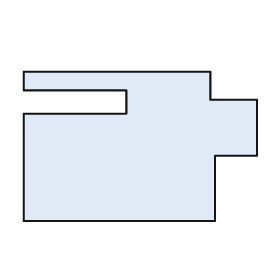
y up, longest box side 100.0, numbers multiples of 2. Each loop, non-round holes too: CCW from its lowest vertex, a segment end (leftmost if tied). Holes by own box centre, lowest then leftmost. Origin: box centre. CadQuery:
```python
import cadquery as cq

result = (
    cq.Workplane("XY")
    .moveTo(-50.0, -32.0)
    .lineTo(32.0, -32.0)
    .lineTo(32.0, -4.0)
    .lineTo(50.0, -4.0)
    .lineTo(50.0, 20.0)
    .lineTo(30.0, 20.0)
    .lineTo(30.0, 32.0)
    .lineTo(-50.0, 32.0)
    .lineTo(-50.0, 24.0)
    .lineTo(-6.0, 24.0)
    .lineTo(-6.0, 14.0)
    .lineTo(-50.0, 14.0)
    .close()
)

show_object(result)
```